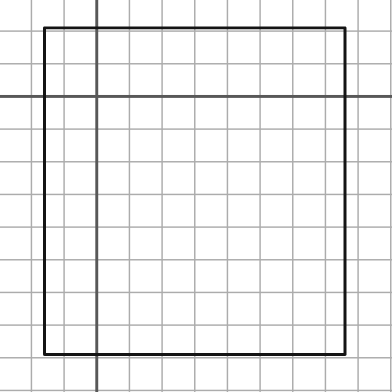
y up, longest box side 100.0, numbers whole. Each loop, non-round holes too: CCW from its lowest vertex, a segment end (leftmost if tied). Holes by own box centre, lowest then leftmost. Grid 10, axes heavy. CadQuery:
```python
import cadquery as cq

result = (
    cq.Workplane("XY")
    .moveTo(-16.0, -79.0)
    .lineTo(76.0, -79.0)
    .lineTo(76.0, 21.0)
    .lineTo(-16.0, 21.0)
    .close()
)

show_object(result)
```